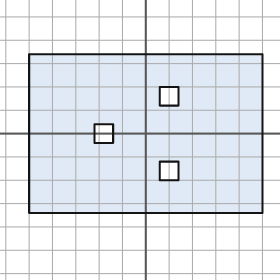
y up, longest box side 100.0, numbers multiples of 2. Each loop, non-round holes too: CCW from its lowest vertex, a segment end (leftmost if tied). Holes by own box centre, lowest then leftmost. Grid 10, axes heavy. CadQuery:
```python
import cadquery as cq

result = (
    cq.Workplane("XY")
    .moveTo(-50.0, -34.0)
    .lineTo(50.0, -34.0)
    .lineTo(50.0, 34.0)
    .lineTo(-50.0, 34.0)
    .close()
    .moveTo(6.0, -20.0)
    .lineTo(14.0, -20.0)
    .lineTo(14.0, -12.0)
    .lineTo(6.0, -12.0)
    .close()
    .moveTo(-22.0, -4.0)
    .lineTo(-14.0, -4.0)
    .lineTo(-14.0, 4.0)
    .lineTo(-22.0, 4.0)
    .close()
    .moveTo(6.0, 12.0)
    .lineTo(14.0, 12.0)
    .lineTo(14.0, 20.0)
    .lineTo(6.0, 20.0)
    .close()
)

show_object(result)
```